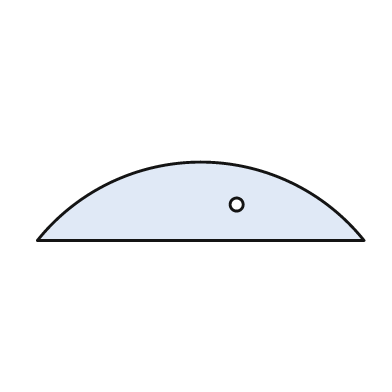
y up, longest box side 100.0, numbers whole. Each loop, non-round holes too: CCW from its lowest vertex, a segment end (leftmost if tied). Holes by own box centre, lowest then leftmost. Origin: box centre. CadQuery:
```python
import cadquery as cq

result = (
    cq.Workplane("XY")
    .moveTo(-50.0, -12.0)
    .lineTo(50.0, -12.0)
    .threePointArc((0.0, 12.0), (-50.0, -12.0))
    .close()
    .moveTo(11.0, -1.0)
    .circle(2.0)
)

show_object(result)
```